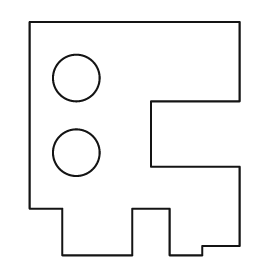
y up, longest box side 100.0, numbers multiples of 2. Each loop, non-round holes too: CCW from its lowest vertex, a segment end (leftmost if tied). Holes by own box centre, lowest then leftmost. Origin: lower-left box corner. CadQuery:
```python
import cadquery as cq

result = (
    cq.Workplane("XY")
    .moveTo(14.0, 0.0)
    .lineTo(44.0, 0.0)
    .lineTo(44.0, 20.0)
    .lineTo(60.0, 20.0)
    .lineTo(60.0, 0.0)
    .lineTo(74.0, 0.0)
    .lineTo(74.0, 4.0)
    .lineTo(90.0, 4.0)
    .lineTo(90.0, 38.0)
    .lineTo(52.0, 38.0)
    .lineTo(52.0, 66.0)
    .lineTo(90.0, 66.0)
    .lineTo(90.0, 100.0)
    .lineTo(0.0, 100.0)
    .lineTo(0.0, 20.0)
    .lineTo(14.0, 20.0)
    .close()
    .moveTo(20.0, 44.0)
    .circle(10.0)
    .moveTo(20.0, 76.0)
    .circle(10.0)
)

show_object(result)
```